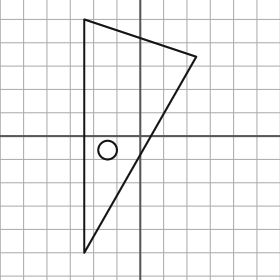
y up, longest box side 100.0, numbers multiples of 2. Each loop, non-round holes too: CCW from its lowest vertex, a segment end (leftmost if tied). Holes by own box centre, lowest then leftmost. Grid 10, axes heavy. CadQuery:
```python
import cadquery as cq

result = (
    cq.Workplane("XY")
    .moveTo(-24.0, -50.0)
    .lineTo(24.0, 34.0)
    .lineTo(-24.0, 50.0)
    .close()
    .moveTo(-14.0, -6.0)
    .circle(4.0)
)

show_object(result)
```